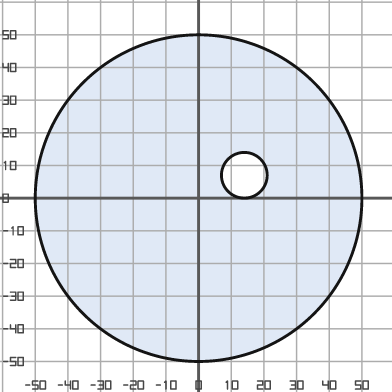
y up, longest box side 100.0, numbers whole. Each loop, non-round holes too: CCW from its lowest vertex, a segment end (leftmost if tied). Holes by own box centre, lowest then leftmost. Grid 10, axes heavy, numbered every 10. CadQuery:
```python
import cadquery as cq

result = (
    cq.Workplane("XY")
    .moveTo(0.0, 0.0)
    .circle(50.0)
    .moveTo(14.0, 7.0)
    .circle(7.0)
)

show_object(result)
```